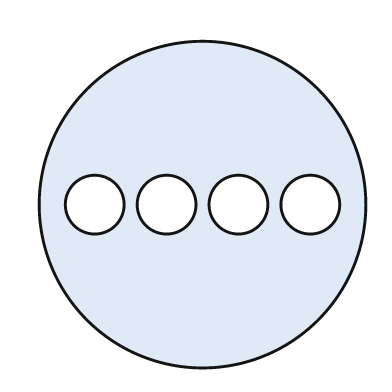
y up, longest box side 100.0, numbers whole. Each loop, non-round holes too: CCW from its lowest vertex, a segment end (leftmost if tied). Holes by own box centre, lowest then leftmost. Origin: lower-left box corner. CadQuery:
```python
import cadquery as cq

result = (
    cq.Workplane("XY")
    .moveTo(50.0, 50.0)
    .circle(50.0)
    .moveTo(17.0, 50.0)
    .circle(9.0)
    .moveTo(39.0, 50.0)
    .circle(9.0)
    .moveTo(61.0, 50.0)
    .circle(9.0)
    .moveTo(83.0, 50.0)
    .circle(9.0)
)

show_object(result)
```